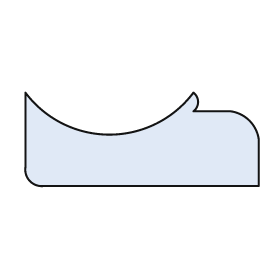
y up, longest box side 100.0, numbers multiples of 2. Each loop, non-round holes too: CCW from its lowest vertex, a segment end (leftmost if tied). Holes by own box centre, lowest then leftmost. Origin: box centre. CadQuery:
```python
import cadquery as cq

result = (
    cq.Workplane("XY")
    .moveTo(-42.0, -20.0)
    .lineTo(50.0, -20.0)
    .lineTo(50.0, 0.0)
    .threePointArc((46.0, 8.0), (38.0, 12.0))
    .lineTo(22.0, 12.0)
    .threePointArc((24.0, 16.0), (22.0, 20.0))
    .threePointArc((-14.0, 2.0), (-50.0, 20.0))
    .lineTo(-50.0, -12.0)
    .threePointArc((-48.0, -18.0), (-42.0, -20.0))
    .close()
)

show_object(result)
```